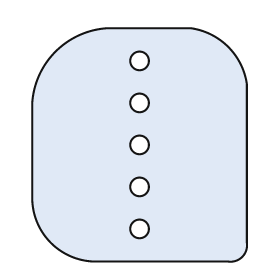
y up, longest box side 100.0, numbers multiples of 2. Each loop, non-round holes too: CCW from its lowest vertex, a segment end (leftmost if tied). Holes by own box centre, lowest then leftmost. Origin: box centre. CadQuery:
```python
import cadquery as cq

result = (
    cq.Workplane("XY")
    .moveTo(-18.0, -50.0)
    .lineTo(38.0, -50.0)
    .threePointArc((44.0, -48.0), (46.0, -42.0))
    .lineTo(46.0, 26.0)
    .threePointArc((38.0, 42.0), (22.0, 50.0))
    .lineTo(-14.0, 50.0)
    .threePointArc((-36.0, 40.0), (-46.0, 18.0))
    .lineTo(-46.0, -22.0)
    .threePointArc((-38.0, -42.0), (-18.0, -50.0))
    .close()
    .moveTo(0.0, -36.0)
    .circle(4.0)
    .moveTo(0.0, -18.0)
    .circle(4.0)
    .moveTo(0.0, 0.0)
    .circle(4.0)
    .moveTo(0.0, 18.0)
    .circle(4.0)
    .moveTo(0.0, 36.0)
    .circle(4.0)
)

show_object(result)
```